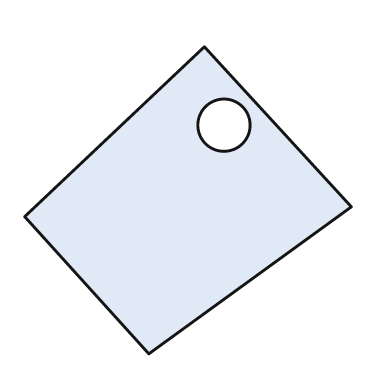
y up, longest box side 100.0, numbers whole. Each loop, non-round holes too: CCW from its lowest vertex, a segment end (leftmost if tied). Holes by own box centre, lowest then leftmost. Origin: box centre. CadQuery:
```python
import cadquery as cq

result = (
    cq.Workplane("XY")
    .moveTo(-12.0, -47.0)
    .lineTo(50.0, -2.0)
    .lineTo(5.0, 47.0)
    .lineTo(-50.0, -5.0)
    .close()
    .moveTo(11.0, 23.0)
    .circle(8.0)
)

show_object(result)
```